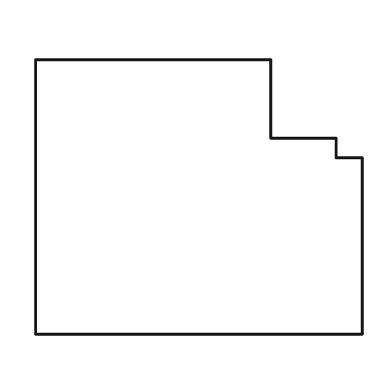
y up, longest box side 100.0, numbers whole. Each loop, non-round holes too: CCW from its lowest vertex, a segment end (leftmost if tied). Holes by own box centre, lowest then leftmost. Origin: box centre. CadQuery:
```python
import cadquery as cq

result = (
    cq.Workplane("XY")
    .moveTo(-50.0, -42.0)
    .lineTo(50.0, -42.0)
    .lineTo(50.0, 12.0)
    .lineTo(42.0, 12.0)
    .lineTo(42.0, 18.0)
    .lineTo(22.0, 18.0)
    .lineTo(22.0, 42.0)
    .lineTo(-50.0, 42.0)
    .close()
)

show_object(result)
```